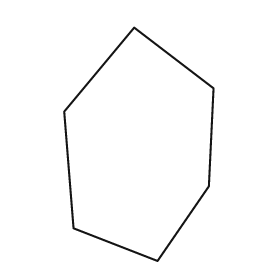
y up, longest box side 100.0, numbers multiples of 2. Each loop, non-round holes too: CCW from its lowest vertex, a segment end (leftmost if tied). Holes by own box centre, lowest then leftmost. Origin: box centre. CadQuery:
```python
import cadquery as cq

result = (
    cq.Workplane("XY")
    .moveTo(8.0, -50.0)
    .lineTo(30.0, -18.0)
    .lineTo(32.0, 24.0)
    .lineTo(-2.0, 50.0)
    .lineTo(-32.0, 14.0)
    .lineTo(-28.0, -36.0)
    .close()
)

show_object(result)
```